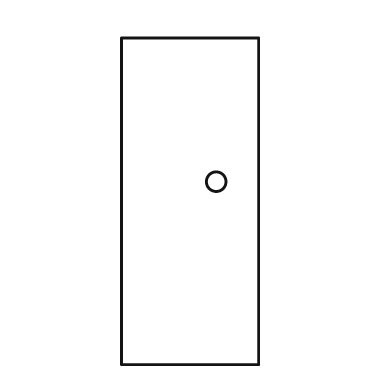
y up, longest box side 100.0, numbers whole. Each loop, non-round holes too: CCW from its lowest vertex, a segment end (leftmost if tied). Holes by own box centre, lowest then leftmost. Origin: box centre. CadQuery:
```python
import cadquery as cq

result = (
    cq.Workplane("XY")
    .moveTo(-21.0, -50.0)
    .lineTo(21.0, -50.0)
    .lineTo(21.0, 50.0)
    .lineTo(-21.0, 50.0)
    .close()
    .moveTo(8.0, 6.0)
    .circle(3.0)
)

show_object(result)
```